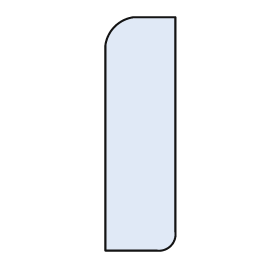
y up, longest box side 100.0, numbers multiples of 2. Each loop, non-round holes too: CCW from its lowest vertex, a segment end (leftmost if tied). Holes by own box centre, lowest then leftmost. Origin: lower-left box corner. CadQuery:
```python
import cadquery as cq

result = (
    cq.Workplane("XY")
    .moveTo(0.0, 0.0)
    .lineTo(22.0, 0.0)
    .threePointArc((28.0, 2.0), (30.0, 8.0))
    .lineTo(30.0, 100.0)
    .lineTo(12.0, 100.0)
    .threePointArc((4.0, 96.0), (0.0, 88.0))
    .close()
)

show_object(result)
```